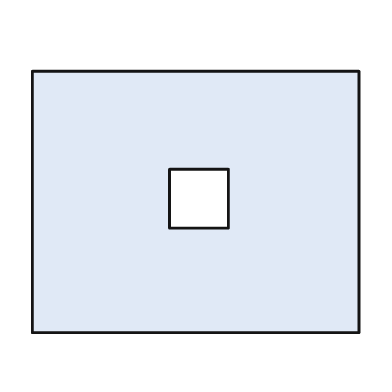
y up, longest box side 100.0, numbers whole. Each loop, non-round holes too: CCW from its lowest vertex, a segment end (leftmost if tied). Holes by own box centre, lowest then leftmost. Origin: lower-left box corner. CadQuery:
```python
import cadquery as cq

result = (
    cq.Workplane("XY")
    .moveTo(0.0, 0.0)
    .lineTo(100.0, 0.0)
    .lineTo(100.0, 80.0)
    .lineTo(0.0, 80.0)
    .close()
    .moveTo(42.0, 32.0)
    .lineTo(60.0, 32.0)
    .lineTo(60.0, 50.0)
    .lineTo(42.0, 50.0)
    .close()
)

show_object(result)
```